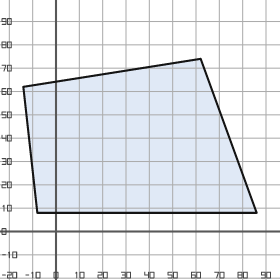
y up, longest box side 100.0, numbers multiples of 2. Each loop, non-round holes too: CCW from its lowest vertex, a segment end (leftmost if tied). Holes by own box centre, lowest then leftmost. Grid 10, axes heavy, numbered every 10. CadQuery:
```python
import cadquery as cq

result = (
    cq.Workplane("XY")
    .moveTo(-8.0, 8.0)
    .lineTo(86.0, 8.0)
    .lineTo(62.0, 74.0)
    .lineTo(-14.0, 62.0)
    .close()
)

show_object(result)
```